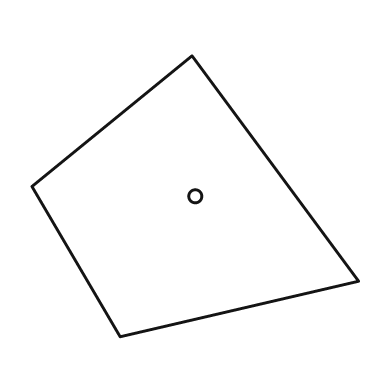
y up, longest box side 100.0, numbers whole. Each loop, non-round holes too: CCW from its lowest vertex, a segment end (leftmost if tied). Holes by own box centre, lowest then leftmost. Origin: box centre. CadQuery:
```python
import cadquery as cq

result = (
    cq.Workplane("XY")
    .moveTo(-23.0, -43.0)
    .lineTo(50.0, -26.0)
    .lineTo(-1.0, 43.0)
    .lineTo(-50.0, 3.0)
    .close()
    .moveTo(0.0, 0.0)
    .circle(2.0)
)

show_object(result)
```